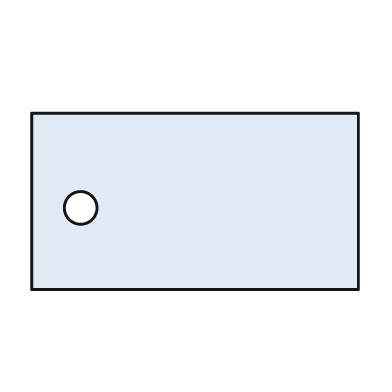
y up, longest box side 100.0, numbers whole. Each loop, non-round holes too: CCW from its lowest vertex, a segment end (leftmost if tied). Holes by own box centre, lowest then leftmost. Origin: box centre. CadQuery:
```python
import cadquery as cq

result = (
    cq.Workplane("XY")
    .moveTo(-50.0, -27.0)
    .lineTo(50.0, -27.0)
    .lineTo(50.0, 27.0)
    .lineTo(-50.0, 27.0)
    .close()
    .moveTo(-35.0, -2.0)
    .circle(5.0)
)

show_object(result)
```